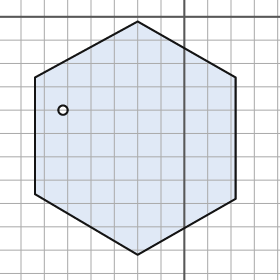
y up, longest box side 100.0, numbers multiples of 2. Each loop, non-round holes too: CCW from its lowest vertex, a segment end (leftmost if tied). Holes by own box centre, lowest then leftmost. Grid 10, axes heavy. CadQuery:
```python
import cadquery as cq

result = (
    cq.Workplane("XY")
    .moveTo(-20.0, -102.0)
    .lineTo(22.0, -78.0)
    .lineTo(22.0, -26.0)
    .lineTo(-20.0, -2.0)
    .lineTo(-64.0, -26.0)
    .lineTo(-64.0, -76.0)
    .close()
    .moveTo(-52.0, -40.0)
    .circle(2.0)
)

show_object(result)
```